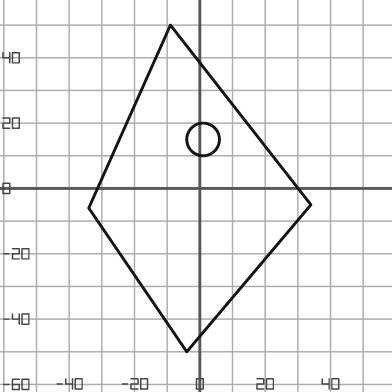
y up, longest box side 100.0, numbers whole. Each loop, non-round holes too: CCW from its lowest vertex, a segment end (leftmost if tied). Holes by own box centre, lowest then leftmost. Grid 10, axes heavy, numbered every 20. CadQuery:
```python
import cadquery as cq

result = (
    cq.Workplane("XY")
    .moveTo(-4.0, -50.0)
    .lineTo(34.0, -5.0)
    .lineTo(-9.0, 50.0)
    .lineTo(-34.0, -6.0)
    .close()
    .moveTo(1.0, 15.0)
    .circle(5.0)
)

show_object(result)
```